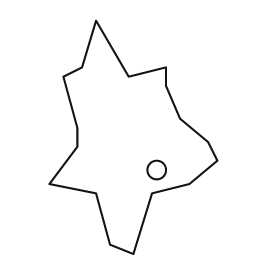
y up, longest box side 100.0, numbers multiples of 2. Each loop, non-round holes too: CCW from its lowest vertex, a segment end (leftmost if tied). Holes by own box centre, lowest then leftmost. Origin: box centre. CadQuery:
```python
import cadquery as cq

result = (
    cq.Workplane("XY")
    .moveTo(0.0, -50.0)
    .lineTo(8.0, -24.0)
    .lineTo(24.0, -20.0)
    .lineTo(36.0, -10.0)
    .lineTo(32.0, -2.0)
    .lineTo(20.0, 8.0)
    .lineTo(14.0, 22.0)
    .lineTo(14.0, 30.0)
    .lineTo(-2.0, 26.0)
    .lineTo(-16.0, 50.0)
    .lineTo(-22.0, 30.0)
    .lineTo(-30.0, 26.0)
    .lineTo(-24.0, 4.0)
    .lineTo(-24.0, -4.0)
    .lineTo(-36.0, -20.0)
    .lineTo(-16.0, -24.0)
    .lineTo(-10.0, -46.0)
    .close()
    .moveTo(10.0, -14.0)
    .circle(4.0)
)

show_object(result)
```